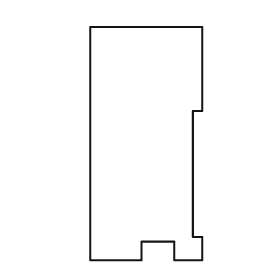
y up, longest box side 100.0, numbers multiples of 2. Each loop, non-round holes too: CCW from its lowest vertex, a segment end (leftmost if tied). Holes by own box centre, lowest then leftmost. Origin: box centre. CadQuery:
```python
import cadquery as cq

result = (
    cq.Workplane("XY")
    .moveTo(-24.0, -50.0)
    .lineTo(-2.0, -50.0)
    .lineTo(-2.0, -42.0)
    .lineTo(12.0, -42.0)
    .lineTo(12.0, -50.0)
    .lineTo(24.0, -50.0)
    .lineTo(24.0, -40.0)
    .lineTo(20.0, -40.0)
    .lineTo(20.0, 14.0)
    .lineTo(24.0, 14.0)
    .lineTo(24.0, 50.0)
    .lineTo(-24.0, 50.0)
    .close()
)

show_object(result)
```